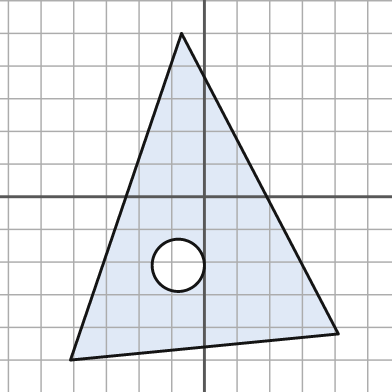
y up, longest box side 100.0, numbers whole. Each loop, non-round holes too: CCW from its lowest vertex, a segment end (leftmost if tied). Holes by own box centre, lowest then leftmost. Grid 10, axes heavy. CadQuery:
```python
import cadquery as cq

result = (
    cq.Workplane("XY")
    .moveTo(-41.0, -50.0)
    .lineTo(41.0, -42.0)
    .lineTo(-7.0, 50.0)
    .close()
    .moveTo(-8.0, -21.0)
    .circle(8.0)
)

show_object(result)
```